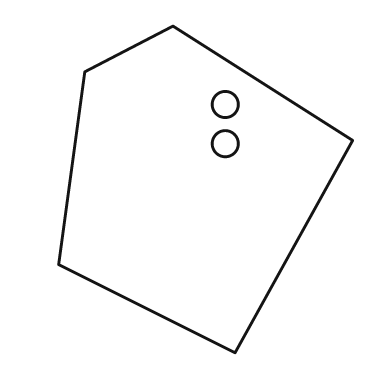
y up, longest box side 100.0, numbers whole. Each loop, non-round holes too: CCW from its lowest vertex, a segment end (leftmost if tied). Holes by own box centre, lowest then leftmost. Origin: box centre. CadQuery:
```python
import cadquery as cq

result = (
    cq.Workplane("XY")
    .moveTo(9.0, -50.0)
    .lineTo(45.0, 15.0)
    .lineTo(-10.0, 50.0)
    .lineTo(-37.0, 36.0)
    .lineTo(-45.0, -23.0)
    .close()
    .moveTo(6.0, 14.0)
    .circle(4.0)
    .moveTo(6.0, 26.0)
    .circle(4.0)
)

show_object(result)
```